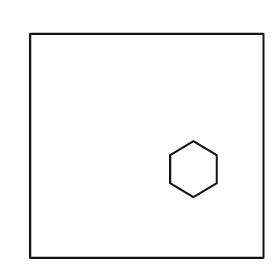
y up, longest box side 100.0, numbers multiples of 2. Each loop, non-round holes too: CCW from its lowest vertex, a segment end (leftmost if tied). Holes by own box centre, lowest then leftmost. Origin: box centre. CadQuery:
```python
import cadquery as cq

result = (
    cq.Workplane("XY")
    .moveTo(-50.0, -48.0)
    .lineTo(50.0, -48.0)
    .lineTo(50.0, 48.0)
    .lineTo(-50.0, 48.0)
    .close()
    .moveTo(20.0, -22.0)
    .lineTo(30.0, -16.0)
    .lineTo(30.0, -4.0)
    .lineTo(20.0, 2.0)
    .lineTo(10.0, -4.0)
    .lineTo(10.0, -16.0)
    .close()
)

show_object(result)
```